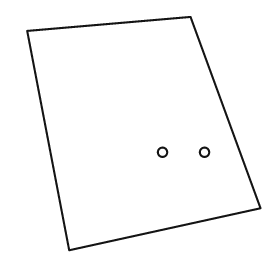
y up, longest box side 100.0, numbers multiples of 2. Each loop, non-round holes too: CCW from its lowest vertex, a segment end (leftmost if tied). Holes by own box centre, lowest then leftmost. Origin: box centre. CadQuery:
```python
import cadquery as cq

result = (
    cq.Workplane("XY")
    .moveTo(-32.0, -50.0)
    .lineTo(50.0, -32.0)
    .lineTo(20.0, 50.0)
    .lineTo(-50.0, 44.0)
    .close()
    .moveTo(8.0, -8.0)
    .circle(2.0)
    .moveTo(26.0, -8.0)
    .circle(2.0)
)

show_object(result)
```